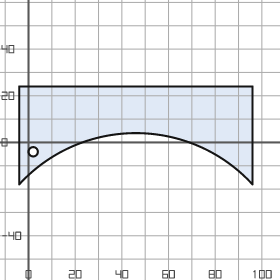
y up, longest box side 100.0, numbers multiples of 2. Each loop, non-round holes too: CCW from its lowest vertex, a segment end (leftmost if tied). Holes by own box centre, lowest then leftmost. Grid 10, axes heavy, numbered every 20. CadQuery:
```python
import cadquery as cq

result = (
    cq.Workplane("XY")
    .moveTo(-4.0, -18.0)
    .threePointArc((46.0, 4.0), (96.0, -18.0))
    .lineTo(96.0, 24.0)
    .lineTo(-4.0, 24.0)
    .close()
    .moveTo(2.0, -4.0)
    .circle(2.0)
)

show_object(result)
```